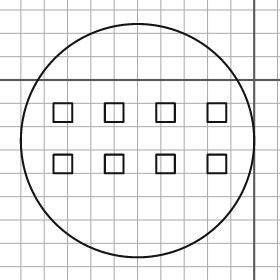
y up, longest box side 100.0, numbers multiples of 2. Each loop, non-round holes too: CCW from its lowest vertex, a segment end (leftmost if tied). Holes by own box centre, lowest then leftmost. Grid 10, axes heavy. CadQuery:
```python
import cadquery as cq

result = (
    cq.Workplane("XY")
    .moveTo(-50.0, -26.0)
    .circle(50.0)
    .moveTo(-86.0, -40.0)
    .lineTo(-78.0, -40.0)
    .lineTo(-78.0, -32.0)
    .lineTo(-86.0, -32.0)
    .close()
    .moveTo(-64.0, -40.0)
    .lineTo(-56.0, -40.0)
    .lineTo(-56.0, -32.0)
    .lineTo(-64.0, -32.0)
    .close()
    .moveTo(-42.0, -40.0)
    .lineTo(-34.0, -40.0)
    .lineTo(-34.0, -32.0)
    .lineTo(-42.0, -32.0)
    .close()
    .moveTo(-20.0, -40.0)
    .lineTo(-12.0, -40.0)
    .lineTo(-12.0, -32.0)
    .lineTo(-20.0, -32.0)
    .close()
    .moveTo(-86.0, -18.0)
    .lineTo(-78.0, -18.0)
    .lineTo(-78.0, -10.0)
    .lineTo(-86.0, -10.0)
    .close()
    .moveTo(-64.0, -18.0)
    .lineTo(-56.0, -18.0)
    .lineTo(-56.0, -10.0)
    .lineTo(-64.0, -10.0)
    .close()
    .moveTo(-42.0, -18.0)
    .lineTo(-34.0, -18.0)
    .lineTo(-34.0, -10.0)
    .lineTo(-42.0, -10.0)
    .close()
    .moveTo(-20.0, -18.0)
    .lineTo(-12.0, -18.0)
    .lineTo(-12.0, -10.0)
    .lineTo(-20.0, -10.0)
    .close()
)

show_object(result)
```